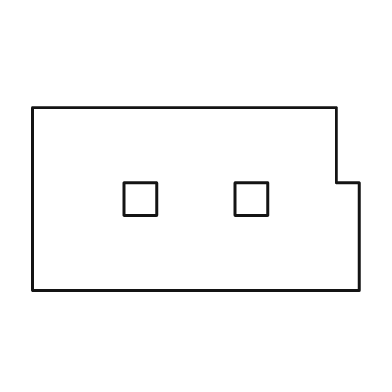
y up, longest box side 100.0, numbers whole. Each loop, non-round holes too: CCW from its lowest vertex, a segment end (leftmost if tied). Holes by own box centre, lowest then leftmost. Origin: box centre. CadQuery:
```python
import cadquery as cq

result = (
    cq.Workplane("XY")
    .moveTo(-50.0, -28.0)
    .lineTo(50.0, -28.0)
    .lineTo(50.0, 5.0)
    .lineTo(43.0, 5.0)
    .lineTo(43.0, 28.0)
    .lineTo(-50.0, 28.0)
    .close()
    .moveTo(-22.0, -5.0)
    .lineTo(-12.0, -5.0)
    .lineTo(-12.0, 5.0)
    .lineTo(-22.0, 5.0)
    .close()
    .moveTo(12.0, -5.0)
    .lineTo(22.0, -5.0)
    .lineTo(22.0, 5.0)
    .lineTo(12.0, 5.0)
    .close()
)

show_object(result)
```